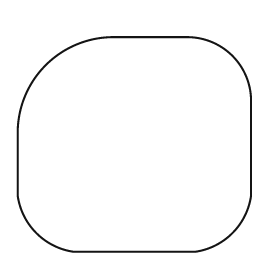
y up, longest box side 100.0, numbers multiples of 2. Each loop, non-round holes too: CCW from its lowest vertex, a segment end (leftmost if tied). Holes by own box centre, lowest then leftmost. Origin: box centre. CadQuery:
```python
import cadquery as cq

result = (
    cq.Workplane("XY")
    .moveTo(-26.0, -46.0)
    .lineTo(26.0, -46.0)
    .threePointArc((42.0, -38.0), (50.0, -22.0))
    .lineTo(50.0, 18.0)
    .threePointArc((42.0, 38.0), (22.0, 46.0))
    .lineTo(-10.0, 46.0)
    .threePointArc((-38.0, 34.0), (-50.0, 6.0))
    .lineTo(-50.0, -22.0)
    .threePointArc((-42.0, -38.0), (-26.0, -46.0))
    .close()
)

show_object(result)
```